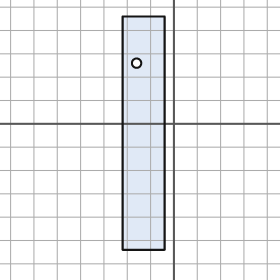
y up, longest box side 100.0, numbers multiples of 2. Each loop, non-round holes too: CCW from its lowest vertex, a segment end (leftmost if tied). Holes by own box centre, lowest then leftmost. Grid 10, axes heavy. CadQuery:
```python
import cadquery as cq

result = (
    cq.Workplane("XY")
    .moveTo(-22.0, -54.0)
    .lineTo(-4.0, -54.0)
    .lineTo(-4.0, 46.0)
    .lineTo(-22.0, 46.0)
    .close()
    .moveTo(-16.0, 26.0)
    .circle(2.0)
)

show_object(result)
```